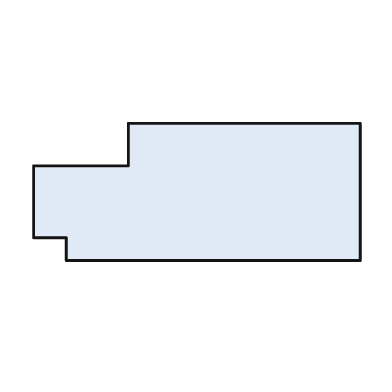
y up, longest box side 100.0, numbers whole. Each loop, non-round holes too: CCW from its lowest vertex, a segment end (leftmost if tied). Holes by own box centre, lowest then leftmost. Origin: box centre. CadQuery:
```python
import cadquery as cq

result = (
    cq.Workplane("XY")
    .moveTo(-40.0, -21.0)
    .lineTo(50.0, -21.0)
    .lineTo(50.0, 21.0)
    .lineTo(-21.0, 21.0)
    .lineTo(-21.0, 8.0)
    .lineTo(-50.0, 8.0)
    .lineTo(-50.0, -14.0)
    .lineTo(-40.0, -14.0)
    .close()
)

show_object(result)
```